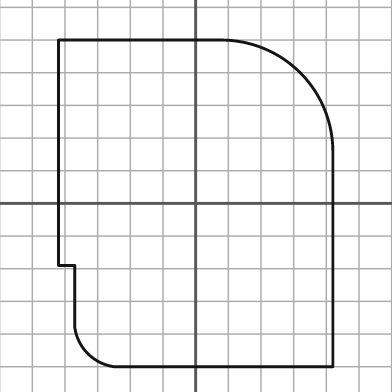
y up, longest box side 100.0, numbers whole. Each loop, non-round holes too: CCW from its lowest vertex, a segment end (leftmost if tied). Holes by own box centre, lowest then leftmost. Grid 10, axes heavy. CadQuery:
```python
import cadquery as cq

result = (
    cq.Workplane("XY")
    .moveTo(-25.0, -50.0)
    .lineTo(42.0, -50.0)
    .lineTo(42.0, 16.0)
    .threePointArc((32.0, 40.0), (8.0, 50.0))
    .lineTo(-42.0, 50.0)
    .lineTo(-42.0, -19.0)
    .lineTo(-37.0, -19.0)
    .lineTo(-37.0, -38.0)
    .threePointArc((-33.0, -46.0), (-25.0, -50.0))
    .close()
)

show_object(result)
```